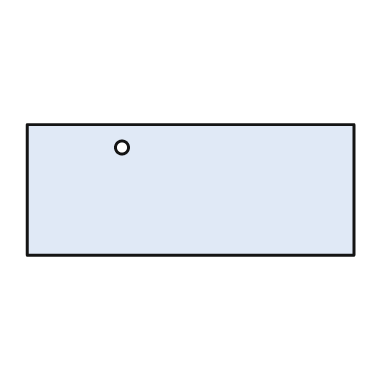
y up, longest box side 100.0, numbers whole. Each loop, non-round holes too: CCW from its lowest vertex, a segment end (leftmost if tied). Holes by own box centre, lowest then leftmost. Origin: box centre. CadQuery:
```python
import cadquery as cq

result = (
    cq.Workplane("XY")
    .moveTo(-50.0, -20.0)
    .lineTo(50.0, -20.0)
    .lineTo(50.0, 20.0)
    .lineTo(-50.0, 20.0)
    .close()
    .moveTo(-21.0, 13.0)
    .circle(2.0)
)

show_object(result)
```